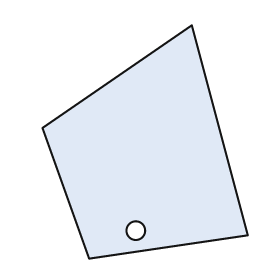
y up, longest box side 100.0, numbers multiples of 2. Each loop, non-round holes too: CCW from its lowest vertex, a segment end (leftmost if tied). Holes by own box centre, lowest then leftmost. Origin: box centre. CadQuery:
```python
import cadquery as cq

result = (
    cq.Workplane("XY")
    .moveTo(-24.0, -50.0)
    .lineTo(44.0, -40.0)
    .lineTo(20.0, 50.0)
    .lineTo(-44.0, 6.0)
    .close()
    .moveTo(-4.0, -38.0)
    .circle(4.0)
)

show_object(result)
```